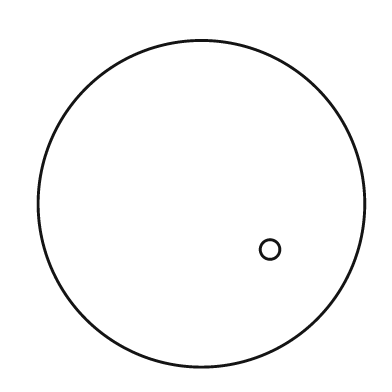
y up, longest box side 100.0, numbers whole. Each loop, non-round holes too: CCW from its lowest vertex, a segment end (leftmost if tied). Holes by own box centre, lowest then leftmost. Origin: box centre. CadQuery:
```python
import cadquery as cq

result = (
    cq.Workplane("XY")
    .moveTo(0.0, 0.0)
    .circle(50.0)
    .moveTo(21.0, -14.0)
    .circle(3.0)
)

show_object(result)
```